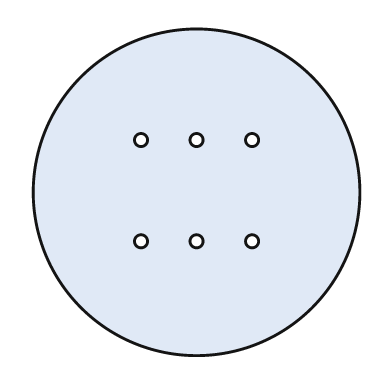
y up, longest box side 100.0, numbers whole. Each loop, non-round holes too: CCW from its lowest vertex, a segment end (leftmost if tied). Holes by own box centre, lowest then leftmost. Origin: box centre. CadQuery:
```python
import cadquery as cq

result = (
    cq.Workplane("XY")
    .moveTo(0.0, 0.0)
    .circle(50.0)
    .moveTo(-17.0, -15.0)
    .circle(2.0)
    .moveTo(0.0, -15.0)
    .circle(2.0)
    .moveTo(17.0, -15.0)
    .circle(2.0)
    .moveTo(-17.0, 16.0)
    .circle(2.0)
    .moveTo(0.0, 16.0)
    .circle(2.0)
    .moveTo(17.0, 16.0)
    .circle(2.0)
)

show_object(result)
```